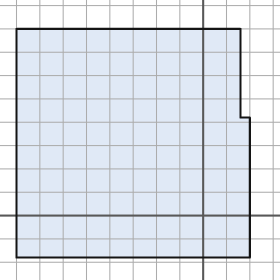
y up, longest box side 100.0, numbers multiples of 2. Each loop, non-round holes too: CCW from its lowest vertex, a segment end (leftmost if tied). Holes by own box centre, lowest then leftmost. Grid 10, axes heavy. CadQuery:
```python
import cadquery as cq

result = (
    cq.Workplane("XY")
    .moveTo(-80.0, -18.0)
    .lineTo(20.0, -18.0)
    .lineTo(20.0, 42.0)
    .lineTo(16.0, 42.0)
    .lineTo(16.0, 80.0)
    .lineTo(-80.0, 80.0)
    .close()
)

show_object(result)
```